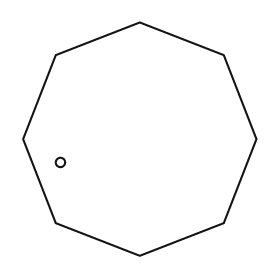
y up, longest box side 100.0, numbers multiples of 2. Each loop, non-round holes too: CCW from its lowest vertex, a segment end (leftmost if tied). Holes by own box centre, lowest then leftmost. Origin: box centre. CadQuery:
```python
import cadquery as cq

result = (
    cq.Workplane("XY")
    .moveTo(0.0, -50.0)
    .lineTo(36.0, -36.0)
    .lineTo(50.0, 0.0)
    .lineTo(36.0, 36.0)
    .lineTo(0.0, 50.0)
    .lineTo(-36.0, 36.0)
    .lineTo(-50.0, 0.0)
    .lineTo(-36.0, -36.0)
    .close()
    .moveTo(-34.0, -10.0)
    .circle(2.0)
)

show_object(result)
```